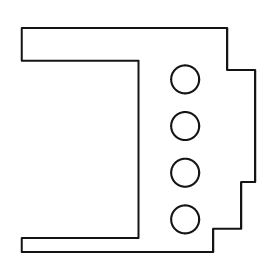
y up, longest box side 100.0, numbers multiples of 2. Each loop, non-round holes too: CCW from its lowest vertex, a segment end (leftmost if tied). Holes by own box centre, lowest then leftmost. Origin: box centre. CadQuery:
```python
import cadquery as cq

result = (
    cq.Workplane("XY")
    .moveTo(-50.0, -48.0)
    .lineTo(32.0, -48.0)
    .lineTo(32.0, -38.0)
    .lineTo(44.0, -38.0)
    .lineTo(44.0, -18.0)
    .lineTo(50.0, -18.0)
    .lineTo(50.0, 30.0)
    .lineTo(38.0, 30.0)
    .lineTo(38.0, 48.0)
    .lineTo(-50.0, 48.0)
    .lineTo(-50.0, 34.0)
    .lineTo(0.0, 34.0)
    .lineTo(0.0, -42.0)
    .lineTo(-50.0, -42.0)
    .close()
    .moveTo(20.0, -34.0)
    .circle(6.0)
    .moveTo(20.0, -14.0)
    .circle(6.0)
    .moveTo(20.0, 6.0)
    .circle(6.0)
    .moveTo(20.0, 26.0)
    .circle(6.0)
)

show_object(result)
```